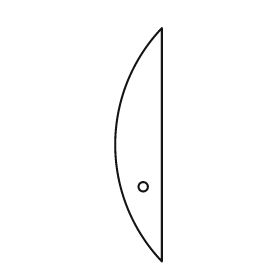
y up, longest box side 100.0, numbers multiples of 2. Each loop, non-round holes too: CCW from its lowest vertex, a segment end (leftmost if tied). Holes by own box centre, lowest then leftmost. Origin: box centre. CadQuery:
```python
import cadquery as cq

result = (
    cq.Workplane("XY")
    .moveTo(10.0, -50.0)
    .lineTo(10.0, 50.0)
    .threePointArc((-10.0, 0.0), (10.0, -50.0))
    .close()
    .moveTo(2.0, -18.0)
    .circle(2.0)
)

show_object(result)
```